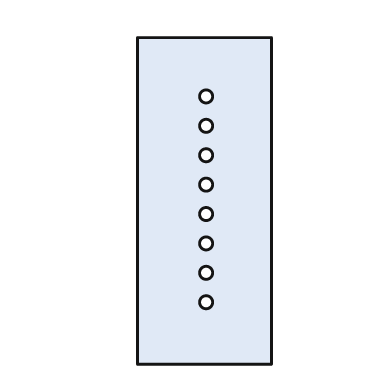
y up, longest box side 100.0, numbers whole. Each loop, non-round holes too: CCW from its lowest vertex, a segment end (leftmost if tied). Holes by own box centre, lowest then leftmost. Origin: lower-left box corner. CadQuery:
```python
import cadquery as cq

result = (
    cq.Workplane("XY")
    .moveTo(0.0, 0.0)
    .lineTo(41.0, 0.0)
    .lineTo(41.0, 100.0)
    .lineTo(0.0, 100.0)
    .close()
    .moveTo(21.0, 19.0)
    .circle(2.0)
    .moveTo(21.0, 28.0)
    .circle(2.0)
    .moveTo(21.0, 37.0)
    .circle(2.0)
    .moveTo(21.0, 46.0)
    .circle(2.0)
    .moveTo(21.0, 55.0)
    .circle(2.0)
    .moveTo(21.0, 64.0)
    .circle(2.0)
    .moveTo(21.0, 73.0)
    .circle(2.0)
    .moveTo(21.0, 82.0)
    .circle(2.0)
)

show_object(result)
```